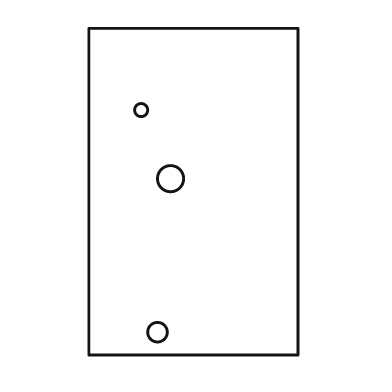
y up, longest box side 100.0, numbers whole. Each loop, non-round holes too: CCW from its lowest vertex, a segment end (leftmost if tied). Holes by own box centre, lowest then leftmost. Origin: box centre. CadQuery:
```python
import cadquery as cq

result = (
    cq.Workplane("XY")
    .moveTo(-32.0, -50.0)
    .lineTo(32.0, -50.0)
    .lineTo(32.0, 50.0)
    .lineTo(-32.0, 50.0)
    .close()
    .moveTo(-11.0, -43.0)
    .circle(3.0)
    .moveTo(-7.0, 4.0)
    .circle(4.0)
    .moveTo(-16.0, 25.0)
    .circle(2.0)
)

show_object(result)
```